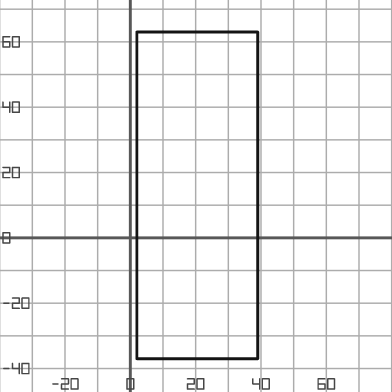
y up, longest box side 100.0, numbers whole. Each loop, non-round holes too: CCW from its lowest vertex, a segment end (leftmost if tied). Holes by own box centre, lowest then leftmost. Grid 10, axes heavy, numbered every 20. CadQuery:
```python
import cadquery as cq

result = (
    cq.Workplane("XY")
    .moveTo(2.0, -37.0)
    .lineTo(39.0, -37.0)
    .lineTo(39.0, 63.0)
    .lineTo(2.0, 63.0)
    .close()
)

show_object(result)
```